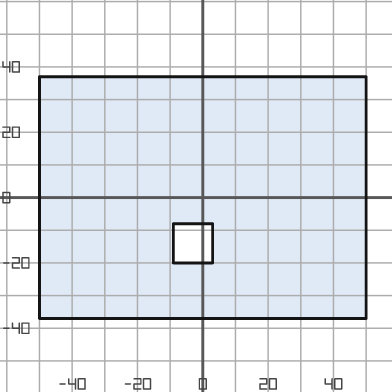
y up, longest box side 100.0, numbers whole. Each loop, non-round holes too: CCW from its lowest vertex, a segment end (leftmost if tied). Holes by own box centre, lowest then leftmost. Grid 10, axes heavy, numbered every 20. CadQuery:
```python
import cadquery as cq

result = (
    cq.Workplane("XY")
    .moveTo(-50.0, -37.0)
    .lineTo(50.0, -37.0)
    .lineTo(50.0, 37.0)
    .lineTo(-50.0, 37.0)
    .close()
    .moveTo(-9.0, -20.0)
    .lineTo(3.0, -20.0)
    .lineTo(3.0, -8.0)
    .lineTo(-9.0, -8.0)
    .close()
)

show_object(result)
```